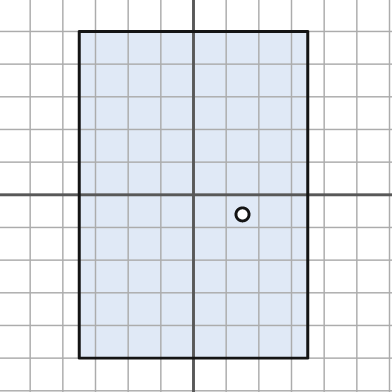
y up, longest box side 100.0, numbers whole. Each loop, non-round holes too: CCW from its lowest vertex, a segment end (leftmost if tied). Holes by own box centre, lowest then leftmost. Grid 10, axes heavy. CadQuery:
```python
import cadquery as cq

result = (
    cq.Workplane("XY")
    .moveTo(-35.0, -50.0)
    .lineTo(35.0, -50.0)
    .lineTo(35.0, 50.0)
    .lineTo(-35.0, 50.0)
    .close()
    .moveTo(15.0, -6.0)
    .circle(2.0)
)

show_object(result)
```